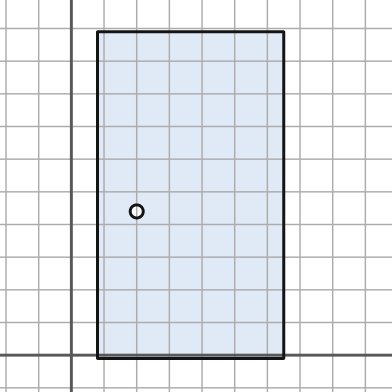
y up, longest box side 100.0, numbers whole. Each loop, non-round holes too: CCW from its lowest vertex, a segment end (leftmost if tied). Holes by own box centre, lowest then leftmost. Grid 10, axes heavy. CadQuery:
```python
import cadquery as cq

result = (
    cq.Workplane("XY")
    .moveTo(8.0, -1.0)
    .lineTo(65.0, -1.0)
    .lineTo(65.0, 99.0)
    .lineTo(8.0, 99.0)
    .close()
    .moveTo(20.0, 44.0)
    .circle(2.0)
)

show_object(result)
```